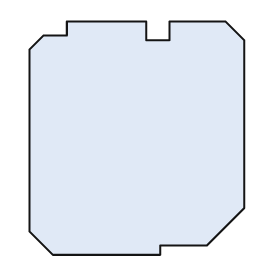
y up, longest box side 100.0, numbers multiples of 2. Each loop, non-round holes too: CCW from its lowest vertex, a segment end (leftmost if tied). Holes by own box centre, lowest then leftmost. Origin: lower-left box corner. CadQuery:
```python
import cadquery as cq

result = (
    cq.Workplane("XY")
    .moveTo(10.0, 0.0)
    .lineTo(56.0, 0.0)
    .lineTo(56.0, 4.0)
    .lineTo(76.0, 4.0)
    .lineTo(92.0, 20.0)
    .lineTo(92.0, 92.0)
    .lineTo(84.0, 100.0)
    .lineTo(60.0, 100.0)
    .lineTo(60.0, 92.0)
    .lineTo(50.0, 92.0)
    .lineTo(50.0, 100.0)
    .lineTo(16.0, 100.0)
    .lineTo(16.0, 94.0)
    .lineTo(6.0, 94.0)
    .lineTo(0.0, 88.0)
    .lineTo(0.0, 10.0)
    .close()
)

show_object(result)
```